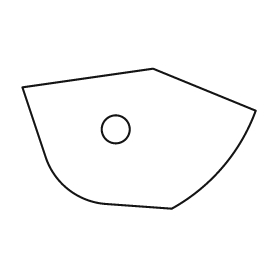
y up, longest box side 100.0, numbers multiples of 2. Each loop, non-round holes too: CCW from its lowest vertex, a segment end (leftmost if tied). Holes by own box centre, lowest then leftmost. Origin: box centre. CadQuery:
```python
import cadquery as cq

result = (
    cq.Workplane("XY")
    .moveTo(14.0, -30.0)
    .threePointArc((36.0, -12.0), (50.0, 12.0))
    .lineTo(6.0, 30.0)
    .lineTo(-50.0, 22.0)
    .lineTo(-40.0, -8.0)
    .threePointArc((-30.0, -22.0), (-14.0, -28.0))
    .close()
    .moveTo(-10.0, 4.0)
    .circle(6.0)
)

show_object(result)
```